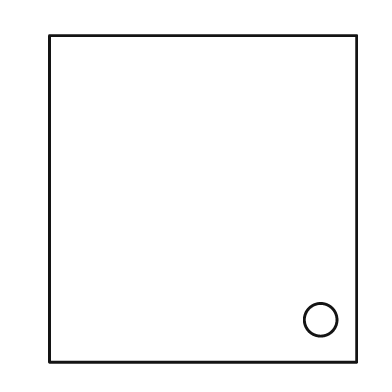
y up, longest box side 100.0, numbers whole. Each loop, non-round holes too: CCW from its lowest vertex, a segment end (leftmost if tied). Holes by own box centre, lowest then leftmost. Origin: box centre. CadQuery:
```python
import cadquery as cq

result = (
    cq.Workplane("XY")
    .moveTo(-47.0, -50.0)
    .lineTo(47.0, -50.0)
    .lineTo(47.0, 50.0)
    .lineTo(-47.0, 50.0)
    .close()
    .moveTo(36.0, -37.0)
    .circle(5.0)
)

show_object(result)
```